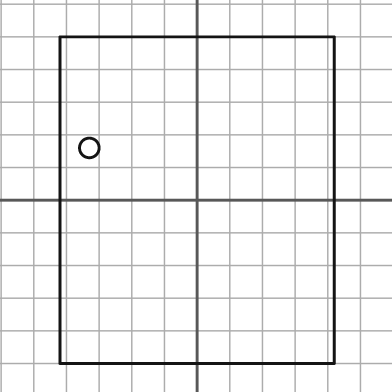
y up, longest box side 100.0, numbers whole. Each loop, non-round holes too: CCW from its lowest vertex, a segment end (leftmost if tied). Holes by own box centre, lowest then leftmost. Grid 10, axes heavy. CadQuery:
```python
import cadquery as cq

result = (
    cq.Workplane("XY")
    .moveTo(-42.0, -50.0)
    .lineTo(42.0, -50.0)
    .lineTo(42.0, 50.0)
    .lineTo(-42.0, 50.0)
    .close()
    .moveTo(-33.0, 16.0)
    .circle(3.0)
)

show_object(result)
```